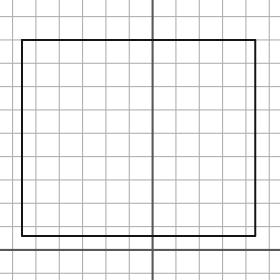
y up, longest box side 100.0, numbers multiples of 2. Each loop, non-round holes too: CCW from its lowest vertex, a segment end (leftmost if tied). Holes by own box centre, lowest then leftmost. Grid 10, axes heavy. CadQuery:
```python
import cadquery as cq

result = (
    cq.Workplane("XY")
    .moveTo(-56.0, 6.0)
    .lineTo(44.0, 6.0)
    .lineTo(44.0, 90.0)
    .lineTo(-56.0, 90.0)
    .close()
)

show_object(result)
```